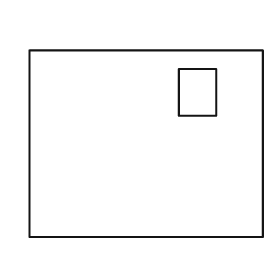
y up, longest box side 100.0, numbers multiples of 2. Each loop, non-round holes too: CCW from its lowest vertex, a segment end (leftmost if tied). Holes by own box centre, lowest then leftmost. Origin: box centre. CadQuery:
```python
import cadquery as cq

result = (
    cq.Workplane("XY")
    .moveTo(-50.0, -40.0)
    .lineTo(50.0, -40.0)
    .lineTo(50.0, 40.0)
    .lineTo(-50.0, 40.0)
    .close()
    .moveTo(14.0, 12.0)
    .lineTo(30.0, 12.0)
    .lineTo(30.0, 32.0)
    .lineTo(14.0, 32.0)
    .close()
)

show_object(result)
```